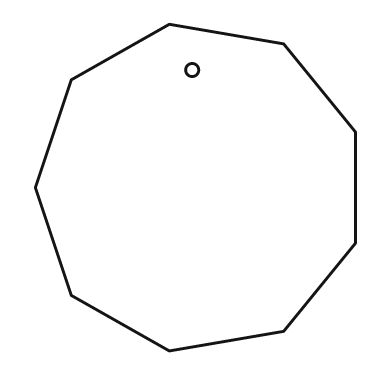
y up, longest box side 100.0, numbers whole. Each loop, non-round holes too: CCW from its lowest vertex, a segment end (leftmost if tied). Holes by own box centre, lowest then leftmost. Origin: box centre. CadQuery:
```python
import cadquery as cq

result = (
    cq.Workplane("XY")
    .moveTo(-8.0, -50.0)
    .lineTo(27.0, -44.0)
    .lineTo(49.0, -17.0)
    .lineTo(49.0, 17.0)
    .lineTo(27.0, 44.0)
    .lineTo(-8.0, 50.0)
    .lineTo(-38.0, 33.0)
    .lineTo(-49.0, 0.0)
    .lineTo(-38.0, -33.0)
    .close()
    .moveTo(-1.0, 36.0)
    .circle(2.0)
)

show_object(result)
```